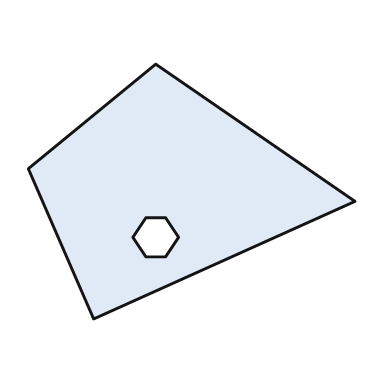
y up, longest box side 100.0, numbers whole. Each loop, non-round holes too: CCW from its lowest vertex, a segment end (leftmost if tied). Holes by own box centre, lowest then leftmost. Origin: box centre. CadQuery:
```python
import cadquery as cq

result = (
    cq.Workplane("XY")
    .moveTo(-30.0, -39.0)
    .lineTo(50.0, -3.0)
    .lineTo(-11.0, 39.0)
    .lineTo(-50.0, 7.0)
    .close()
    .moveTo(-14.0, -20.0)
    .lineTo(-8.0, -20.0)
    .lineTo(-4.0, -14.0)
    .lineTo(-8.0, -8.0)
    .lineTo(-14.0, -8.0)
    .lineTo(-18.0, -14.0)
    .close()
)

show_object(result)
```